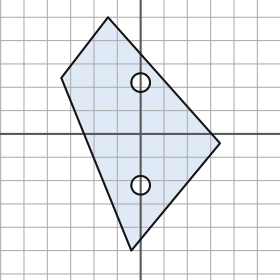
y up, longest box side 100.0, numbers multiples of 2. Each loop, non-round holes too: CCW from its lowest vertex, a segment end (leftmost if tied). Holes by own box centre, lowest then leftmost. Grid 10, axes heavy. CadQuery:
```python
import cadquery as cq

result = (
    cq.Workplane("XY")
    .moveTo(-4.0, -50.0)
    .lineTo(34.0, -4.0)
    .lineTo(-14.0, 50.0)
    .lineTo(-34.0, 24.0)
    .close()
    .moveTo(0.0, -22.0)
    .circle(4.0)
    .moveTo(0.0, 22.0)
    .circle(4.0)
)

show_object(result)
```